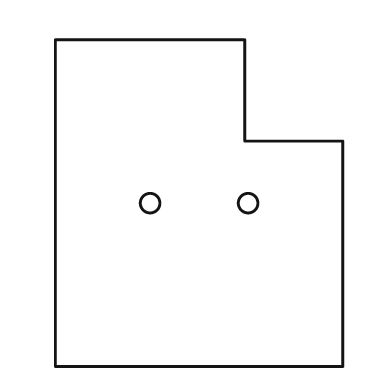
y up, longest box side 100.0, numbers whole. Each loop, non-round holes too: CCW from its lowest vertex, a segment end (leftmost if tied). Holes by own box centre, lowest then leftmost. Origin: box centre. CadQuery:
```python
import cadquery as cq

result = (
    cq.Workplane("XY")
    .moveTo(-44.0, -50.0)
    .lineTo(44.0, -50.0)
    .lineTo(44.0, 19.0)
    .lineTo(14.0, 19.0)
    .lineTo(14.0, 50.0)
    .lineTo(-44.0, 50.0)
    .close()
    .moveTo(-15.0, 0.0)
    .circle(3.0)
    .moveTo(15.0, 0.0)
    .circle(3.0)
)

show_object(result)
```